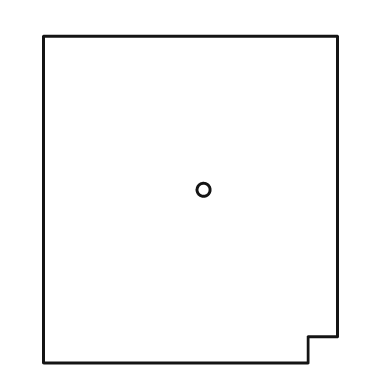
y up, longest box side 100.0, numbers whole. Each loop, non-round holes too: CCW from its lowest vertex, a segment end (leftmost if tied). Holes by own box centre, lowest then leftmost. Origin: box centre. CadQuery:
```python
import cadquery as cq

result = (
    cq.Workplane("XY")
    .moveTo(-45.0, -50.0)
    .lineTo(36.0, -50.0)
    .lineTo(36.0, -42.0)
    .lineTo(45.0, -42.0)
    .lineTo(45.0, 50.0)
    .lineTo(-45.0, 50.0)
    .close()
    .moveTo(4.0, 3.0)
    .circle(2.0)
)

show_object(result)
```